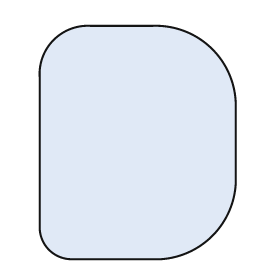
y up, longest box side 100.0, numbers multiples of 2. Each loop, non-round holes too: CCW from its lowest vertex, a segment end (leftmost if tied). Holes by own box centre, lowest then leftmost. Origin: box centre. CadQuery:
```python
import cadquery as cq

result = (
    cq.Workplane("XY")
    .moveTo(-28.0, -50.0)
    .lineTo(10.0, -50.0)
    .threePointArc((32.0, -40.0), (42.0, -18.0))
    .lineTo(42.0, 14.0)
    .threePointArc((32.0, 40.0), (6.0, 50.0))
    .lineTo(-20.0, 50.0)
    .threePointArc((-36.0, 44.0), (-42.0, 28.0))
    .lineTo(-42.0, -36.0)
    .threePointArc((-38.0, -46.0), (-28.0, -50.0))
    .close()
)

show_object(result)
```